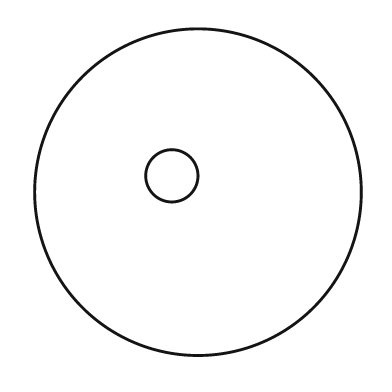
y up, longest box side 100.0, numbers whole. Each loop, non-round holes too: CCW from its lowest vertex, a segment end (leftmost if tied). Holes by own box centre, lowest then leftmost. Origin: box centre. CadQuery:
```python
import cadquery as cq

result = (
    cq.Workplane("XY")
    .moveTo(0.0, 0.0)
    .circle(50.0)
    .moveTo(-8.0, 5.0)
    .circle(8.0)
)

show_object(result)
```